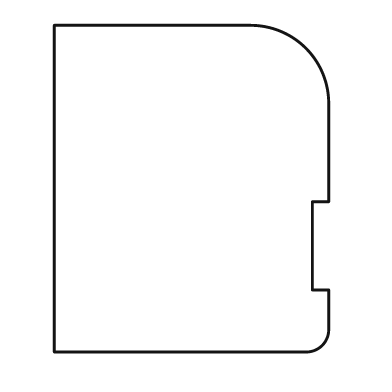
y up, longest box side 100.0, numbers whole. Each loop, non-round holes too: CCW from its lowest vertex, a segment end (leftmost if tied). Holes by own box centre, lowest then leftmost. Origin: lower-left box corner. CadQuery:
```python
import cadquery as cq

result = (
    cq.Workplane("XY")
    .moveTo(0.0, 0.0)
    .lineTo(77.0, 0.0)
    .threePointArc((82.0, 2.0), (84.0, 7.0))
    .lineTo(84.0, 19.0)
    .lineTo(79.0, 19.0)
    .lineTo(79.0, 46.0)
    .lineTo(84.0, 46.0)
    .lineTo(84.0, 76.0)
    .threePointArc((77.0, 93.0), (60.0, 100.0))
    .lineTo(0.0, 100.0)
    .close()
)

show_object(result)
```